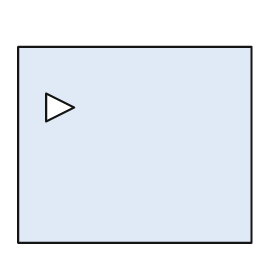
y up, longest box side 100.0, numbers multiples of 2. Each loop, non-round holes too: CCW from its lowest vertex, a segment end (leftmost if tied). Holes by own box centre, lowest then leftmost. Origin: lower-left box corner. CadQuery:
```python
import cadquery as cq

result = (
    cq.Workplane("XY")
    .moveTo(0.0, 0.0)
    .lineTo(100.0, 0.0)
    .lineTo(100.0, 84.0)
    .lineTo(0.0, 84.0)
    .close()
    .moveTo(12.0, 52.0)
    .lineTo(24.0, 58.0)
    .lineTo(12.0, 64.0)
    .close()
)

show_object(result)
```